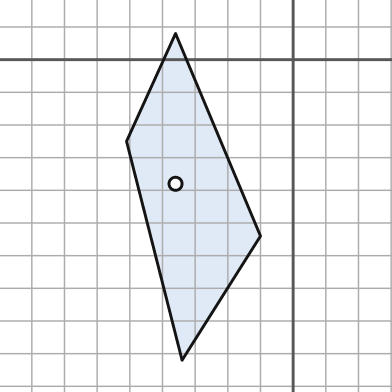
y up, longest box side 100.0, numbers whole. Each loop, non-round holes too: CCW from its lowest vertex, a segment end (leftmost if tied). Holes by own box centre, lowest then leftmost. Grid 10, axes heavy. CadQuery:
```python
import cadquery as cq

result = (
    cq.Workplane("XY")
    .moveTo(-34.0, -92.0)
    .lineTo(-10.0, -54.0)
    .lineTo(-36.0, 8.0)
    .lineTo(-51.0, -25.0)
    .close()
    .moveTo(-36.0, -38.0)
    .circle(2.0)
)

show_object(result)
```